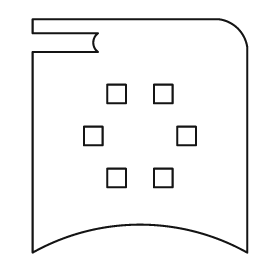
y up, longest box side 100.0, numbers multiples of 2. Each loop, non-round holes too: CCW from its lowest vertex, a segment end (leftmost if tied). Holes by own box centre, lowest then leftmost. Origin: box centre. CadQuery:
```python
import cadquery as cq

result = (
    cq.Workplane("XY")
    .moveTo(-46.0, -50.0)
    .threePointArc((0.0, -38.0), (46.0, -50.0))
    .lineTo(46.0, 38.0)
    .threePointArc((42.0, 46.0), (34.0, 50.0))
    .lineTo(-46.0, 50.0)
    .lineTo(-46.0, 44.0)
    .lineTo(-18.0, 44.0)
    .threePointArc((-20.0, 40.0), (-18.0, 36.0))
    .lineTo(-46.0, 36.0)
    .close()
    .moveTo(-14.0, -22.0)
    .lineTo(-6.0, -22.0)
    .lineTo(-6.0, -14.0)
    .lineTo(-14.0, -14.0)
    .close()
    .moveTo(6.0, -22.0)
    .lineTo(14.0, -22.0)
    .lineTo(14.0, -14.0)
    .lineTo(6.0, -14.0)
    .close()
    .moveTo(-24.0, -4.0)
    .lineTo(-16.0, -4.0)
    .lineTo(-16.0, 4.0)
    .lineTo(-24.0, 4.0)
    .close()
    .moveTo(16.0, -4.0)
    .lineTo(24.0, -4.0)
    .lineTo(24.0, 4.0)
    .lineTo(16.0, 4.0)
    .close()
    .moveTo(-14.0, 14.0)
    .lineTo(-6.0, 14.0)
    .lineTo(-6.0, 22.0)
    .lineTo(-14.0, 22.0)
    .close()
    .moveTo(6.0, 14.0)
    .lineTo(14.0, 14.0)
    .lineTo(14.0, 22.0)
    .lineTo(6.0, 22.0)
    .close()
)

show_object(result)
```